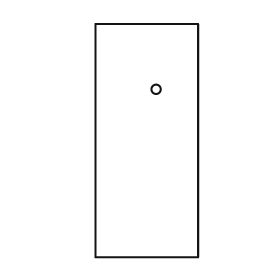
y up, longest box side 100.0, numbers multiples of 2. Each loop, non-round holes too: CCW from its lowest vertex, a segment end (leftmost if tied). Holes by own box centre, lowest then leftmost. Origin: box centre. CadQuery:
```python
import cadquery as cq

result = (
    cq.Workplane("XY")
    .moveTo(-22.0, -50.0)
    .lineTo(22.0, -50.0)
    .lineTo(22.0, 50.0)
    .lineTo(-22.0, 50.0)
    .close()
    .moveTo(4.0, 22.0)
    .circle(2.0)
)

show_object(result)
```